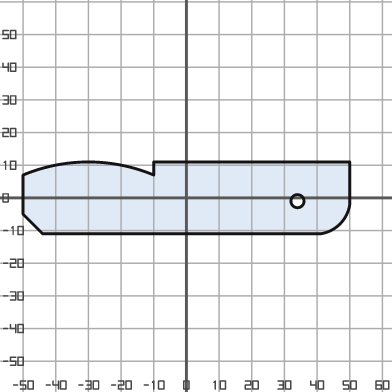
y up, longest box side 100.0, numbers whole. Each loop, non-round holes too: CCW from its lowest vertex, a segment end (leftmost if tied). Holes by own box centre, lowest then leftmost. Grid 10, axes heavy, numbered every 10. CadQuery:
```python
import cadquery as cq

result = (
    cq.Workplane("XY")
    .moveTo(-44.0, -11.0)
    .lineTo(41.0, -11.0)
    .threePointArc((47.0, -8.0), (50.0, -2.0))
    .lineTo(50.0, 11.0)
    .lineTo(-10.0, 11.0)
    .lineTo(-10.0, 7.0)
    .threePointArc((-30.0, 11.0), (-50.0, 7.0))
    .lineTo(-50.0, -5.0)
    .close()
    .moveTo(34.0, -1.0)
    .circle(2.0)
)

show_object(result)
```